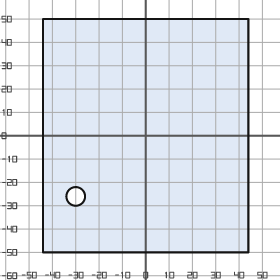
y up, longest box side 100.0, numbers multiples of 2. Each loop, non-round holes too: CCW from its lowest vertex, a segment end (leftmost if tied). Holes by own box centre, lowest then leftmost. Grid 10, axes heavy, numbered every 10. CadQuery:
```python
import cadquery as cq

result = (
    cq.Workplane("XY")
    .moveTo(-44.0, -50.0)
    .lineTo(44.0, -50.0)
    .lineTo(44.0, 50.0)
    .lineTo(-44.0, 50.0)
    .close()
    .moveTo(-30.0, -26.0)
    .circle(4.0)
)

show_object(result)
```